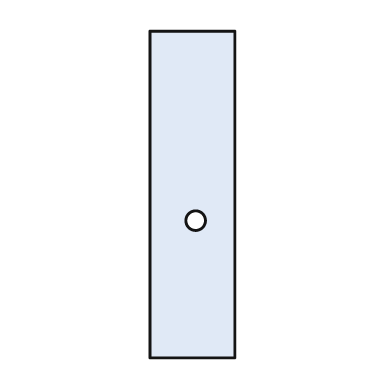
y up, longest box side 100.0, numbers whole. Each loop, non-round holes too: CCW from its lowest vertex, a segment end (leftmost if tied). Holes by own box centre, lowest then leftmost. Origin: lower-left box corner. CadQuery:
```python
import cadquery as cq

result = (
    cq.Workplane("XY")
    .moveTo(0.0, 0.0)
    .lineTo(26.0, 0.0)
    .lineTo(26.0, 100.0)
    .lineTo(0.0, 100.0)
    .close()
    .moveTo(14.0, 42.0)
    .circle(3.0)
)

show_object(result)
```